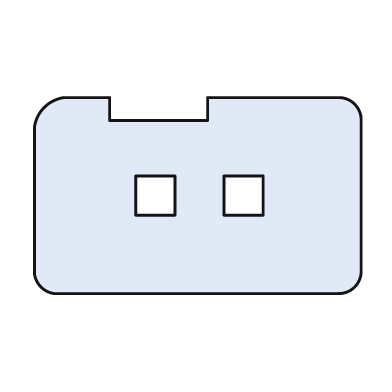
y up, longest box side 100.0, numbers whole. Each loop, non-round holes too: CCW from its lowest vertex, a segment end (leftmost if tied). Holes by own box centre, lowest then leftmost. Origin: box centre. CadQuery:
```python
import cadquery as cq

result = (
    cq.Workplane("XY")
    .moveTo(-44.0, -30.0)
    .lineTo(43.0, -30.0)
    .threePointArc((48.0, -28.0), (50.0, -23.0))
    .lineTo(50.0, 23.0)
    .threePointArc((48.0, 28.0), (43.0, 30.0))
    .lineTo(3.0, 30.0)
    .lineTo(3.0, 23.0)
    .lineTo(-27.0, 23.0)
    .lineTo(-27.0, 30.0)
    .lineTo(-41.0, 30.0)
    .threePointArc((-47.0, 27.0), (-50.0, 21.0))
    .lineTo(-50.0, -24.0)
    .threePointArc((-48.0, -28.0), (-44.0, -30.0))
    .close()
    .moveTo(-19.0, -6.0)
    .lineTo(-7.0, -6.0)
    .lineTo(-7.0, 6.0)
    .lineTo(-19.0, 6.0)
    .close()
    .moveTo(8.0, -6.0)
    .lineTo(20.0, -6.0)
    .lineTo(20.0, 6.0)
    .lineTo(8.0, 6.0)
    .close()
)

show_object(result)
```